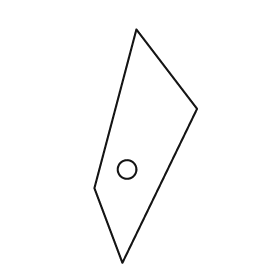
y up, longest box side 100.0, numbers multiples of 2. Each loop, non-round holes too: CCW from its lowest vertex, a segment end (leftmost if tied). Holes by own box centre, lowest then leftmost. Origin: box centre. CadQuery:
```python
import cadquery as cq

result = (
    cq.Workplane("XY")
    .moveTo(-10.0, -50.0)
    .lineTo(22.0, 16.0)
    .lineTo(-4.0, 50.0)
    .lineTo(-22.0, -18.0)
    .close()
    .moveTo(-8.0, -10.0)
    .circle(4.0)
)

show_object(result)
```